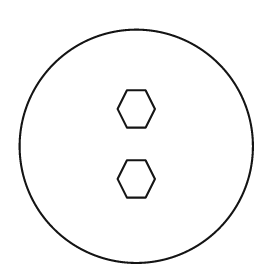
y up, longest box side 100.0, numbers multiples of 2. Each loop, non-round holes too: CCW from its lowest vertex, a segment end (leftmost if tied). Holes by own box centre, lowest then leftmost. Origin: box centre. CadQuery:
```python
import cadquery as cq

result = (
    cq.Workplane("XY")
    .moveTo(0.0, 0.0)
    .circle(50.0)
    .moveTo(-4.0, -22.0)
    .lineTo(4.0, -22.0)
    .lineTo(8.0, -14.0)
    .lineTo(4.0, -6.0)
    .lineTo(-4.0, -6.0)
    .lineTo(-8.0, -14.0)
    .close()
    .moveTo(-4.0, 8.0)
    .lineTo(4.0, 8.0)
    .lineTo(8.0, 16.0)
    .lineTo(4.0, 24.0)
    .lineTo(-4.0, 24.0)
    .lineTo(-8.0, 16.0)
    .close()
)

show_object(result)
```